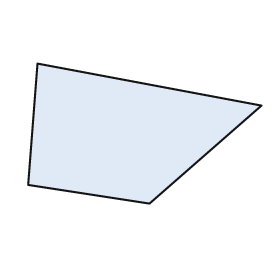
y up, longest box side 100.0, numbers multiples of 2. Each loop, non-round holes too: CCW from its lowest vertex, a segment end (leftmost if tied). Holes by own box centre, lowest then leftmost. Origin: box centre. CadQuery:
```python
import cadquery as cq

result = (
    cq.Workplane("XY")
    .moveTo(2.0, -30.0)
    .lineTo(50.0, 12.0)
    .lineTo(-46.0, 30.0)
    .lineTo(-50.0, -22.0)
    .close()
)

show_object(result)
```